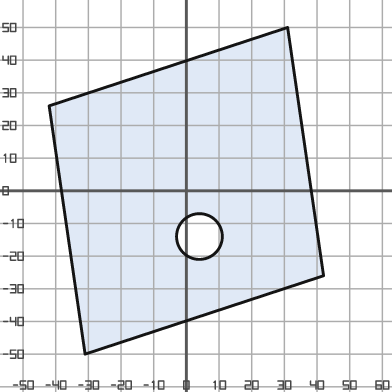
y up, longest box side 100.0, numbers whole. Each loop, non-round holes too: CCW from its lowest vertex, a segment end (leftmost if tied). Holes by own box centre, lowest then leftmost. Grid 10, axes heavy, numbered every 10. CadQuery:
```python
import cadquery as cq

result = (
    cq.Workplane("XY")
    .moveTo(-31.0, -50.0)
    .lineTo(42.0, -26.0)
    .lineTo(31.0, 50.0)
    .lineTo(-42.0, 26.0)
    .close()
    .moveTo(4.0, -14.0)
    .circle(7.0)
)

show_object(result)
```